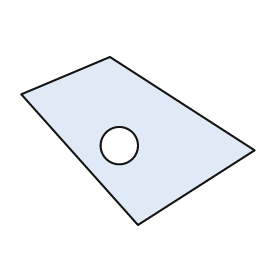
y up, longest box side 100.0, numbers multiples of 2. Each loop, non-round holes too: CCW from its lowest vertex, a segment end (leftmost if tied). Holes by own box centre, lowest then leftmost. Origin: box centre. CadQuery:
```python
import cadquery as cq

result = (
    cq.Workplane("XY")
    .moveTo(0.0, -36.0)
    .lineTo(50.0, -4.0)
    .lineTo(-12.0, 36.0)
    .lineTo(-50.0, 20.0)
    .close()
    .moveTo(-8.0, -2.0)
    .circle(8.0)
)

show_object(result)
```